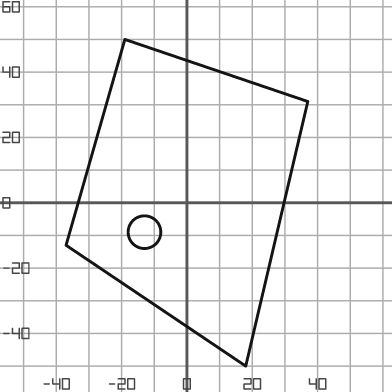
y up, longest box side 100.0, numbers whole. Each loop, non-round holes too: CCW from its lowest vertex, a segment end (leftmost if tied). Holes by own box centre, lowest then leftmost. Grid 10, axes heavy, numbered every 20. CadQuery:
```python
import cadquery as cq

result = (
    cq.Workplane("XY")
    .moveTo(18.0, -50.0)
    .lineTo(37.0, 31.0)
    .lineTo(-19.0, 50.0)
    .lineTo(-37.0, -13.0)
    .close()
    .moveTo(-13.0, -9.0)
    .circle(5.0)
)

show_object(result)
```